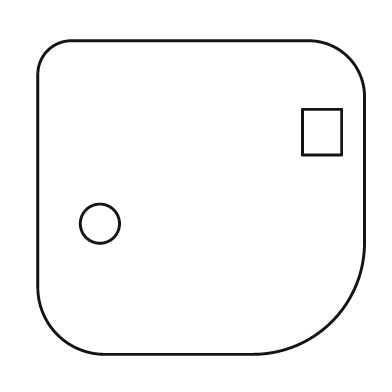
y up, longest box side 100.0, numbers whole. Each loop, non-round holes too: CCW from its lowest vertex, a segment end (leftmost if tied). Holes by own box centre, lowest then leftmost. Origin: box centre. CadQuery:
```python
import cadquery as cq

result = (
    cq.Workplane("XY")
    .moveTo(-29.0, -48.0)
    .lineTo(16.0, -48.0)
    .threePointArc((40.0, -38.0), (50.0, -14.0))
    .lineTo(50.0, 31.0)
    .threePointArc((45.0, 43.0), (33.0, 48.0))
    .lineTo(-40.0, 48.0)
    .threePointArc((-47.0, 45.0), (-50.0, 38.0))
    .lineTo(-50.0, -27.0)
    .threePointArc((-44.0, -42.0), (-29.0, -48.0))
    .close()
    .moveTo(-31.0, -8.0)
    .circle(6.0)
    .moveTo(31.0, 13.0)
    .lineTo(43.0, 13.0)
    .lineTo(43.0, 27.0)
    .lineTo(31.0, 27.0)
    .close()
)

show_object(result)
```